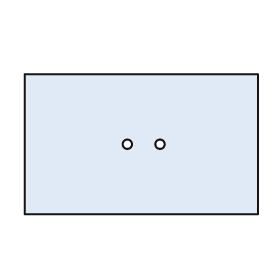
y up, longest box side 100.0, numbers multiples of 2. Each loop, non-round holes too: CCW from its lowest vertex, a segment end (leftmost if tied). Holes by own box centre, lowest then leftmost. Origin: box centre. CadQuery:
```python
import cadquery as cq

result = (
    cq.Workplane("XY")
    .moveTo(-50.0, -30.0)
    .lineTo(50.0, -30.0)
    .lineTo(50.0, 30.0)
    .lineTo(-50.0, 30.0)
    .close()
    .moveTo(-6.0, 0.0)
    .circle(2.0)
    .moveTo(8.0, 0.0)
    .circle(2.0)
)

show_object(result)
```